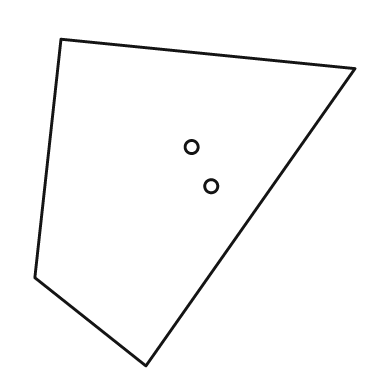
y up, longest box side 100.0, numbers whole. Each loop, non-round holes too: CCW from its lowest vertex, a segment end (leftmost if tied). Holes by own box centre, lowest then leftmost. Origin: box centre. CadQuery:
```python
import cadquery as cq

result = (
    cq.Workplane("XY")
    .moveTo(-15.0, -50.0)
    .lineTo(49.0, 41.0)
    .lineTo(-41.0, 50.0)
    .lineTo(-49.0, -23.0)
    .close()
    .moveTo(5.0, 5.0)
    .circle(2.0)
    .moveTo(-1.0, 17.0)
    .circle(2.0)
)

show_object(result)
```